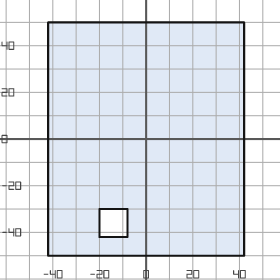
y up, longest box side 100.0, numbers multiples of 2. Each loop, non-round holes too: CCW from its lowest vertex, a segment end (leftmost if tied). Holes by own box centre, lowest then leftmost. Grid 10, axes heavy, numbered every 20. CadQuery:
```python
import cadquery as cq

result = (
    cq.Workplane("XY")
    .moveTo(-42.0, -50.0)
    .lineTo(42.0, -50.0)
    .lineTo(42.0, 50.0)
    .lineTo(-42.0, 50.0)
    .close()
    .moveTo(-20.0, -42.0)
    .lineTo(-8.0, -42.0)
    .lineTo(-8.0, -30.0)
    .lineTo(-20.0, -30.0)
    .close()
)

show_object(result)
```